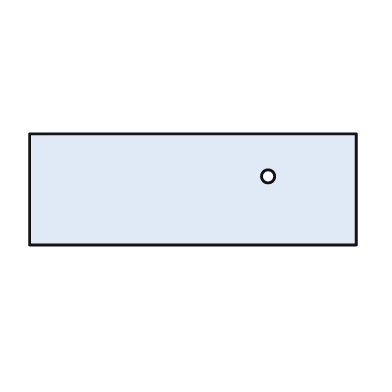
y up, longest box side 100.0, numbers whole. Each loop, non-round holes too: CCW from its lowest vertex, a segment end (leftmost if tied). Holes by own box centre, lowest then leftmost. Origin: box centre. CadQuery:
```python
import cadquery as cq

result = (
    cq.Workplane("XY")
    .moveTo(-50.0, -17.0)
    .lineTo(50.0, -17.0)
    .lineTo(50.0, 17.0)
    .lineTo(-50.0, 17.0)
    .close()
    .moveTo(23.0, 4.0)
    .circle(2.0)
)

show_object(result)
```